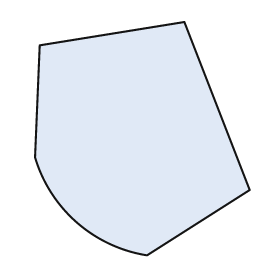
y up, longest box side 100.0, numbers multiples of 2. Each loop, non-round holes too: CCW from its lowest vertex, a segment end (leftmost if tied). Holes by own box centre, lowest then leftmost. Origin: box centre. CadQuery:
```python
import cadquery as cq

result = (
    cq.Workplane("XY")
    .moveTo(2.0, -50.0)
    .lineTo(46.0, -22.0)
    .lineTo(18.0, 50.0)
    .lineTo(-44.0, 40.0)
    .lineTo(-46.0, -8.0)
    .threePointArc((-28.0, -36.0), (2.0, -50.0))
    .close()
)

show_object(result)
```